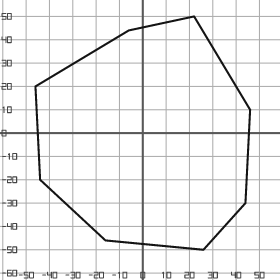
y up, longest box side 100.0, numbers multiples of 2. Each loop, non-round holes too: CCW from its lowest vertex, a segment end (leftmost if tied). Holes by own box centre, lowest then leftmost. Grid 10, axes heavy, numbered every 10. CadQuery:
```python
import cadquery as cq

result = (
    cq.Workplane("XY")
    .moveTo(26.0, -50.0)
    .lineTo(44.0, -30.0)
    .lineTo(46.0, 10.0)
    .lineTo(22.0, 50.0)
    .lineTo(-6.0, 44.0)
    .lineTo(-46.0, 20.0)
    .lineTo(-44.0, -20.0)
    .lineTo(-16.0, -46.0)
    .close()
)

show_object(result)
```